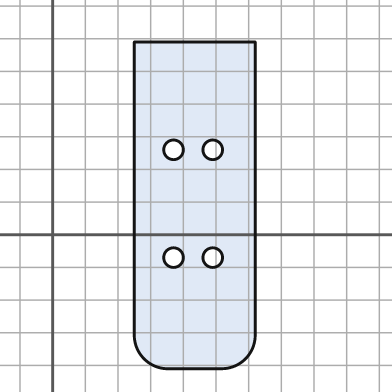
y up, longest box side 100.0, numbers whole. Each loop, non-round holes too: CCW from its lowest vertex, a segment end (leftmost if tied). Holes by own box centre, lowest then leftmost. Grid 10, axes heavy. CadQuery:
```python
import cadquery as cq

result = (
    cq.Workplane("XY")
    .moveTo(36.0, -41.0)
    .lineTo(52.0, -41.0)
    .threePointArc((59.0, -38.0), (62.0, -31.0))
    .lineTo(62.0, 59.0)
    .lineTo(25.0, 59.0)
    .lineTo(25.0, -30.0)
    .threePointArc((28.0, -38.0), (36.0, -41.0))
    .close()
    .moveTo(37.0, -7.0)
    .circle(3.0)
    .moveTo(49.0, -7.0)
    .circle(3.0)
    .moveTo(37.0, 26.0)
    .circle(3.0)
    .moveTo(49.0, 26.0)
    .circle(3.0)
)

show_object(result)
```